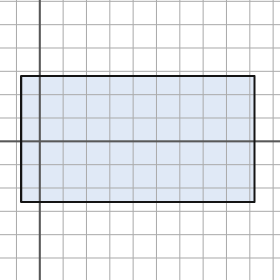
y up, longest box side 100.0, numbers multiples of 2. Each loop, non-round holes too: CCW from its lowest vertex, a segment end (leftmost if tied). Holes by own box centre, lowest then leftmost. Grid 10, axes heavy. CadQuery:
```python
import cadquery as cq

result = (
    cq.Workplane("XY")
    .moveTo(-8.0, -26.0)
    .lineTo(92.0, -26.0)
    .lineTo(92.0, 28.0)
    .lineTo(-8.0, 28.0)
    .close()
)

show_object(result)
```